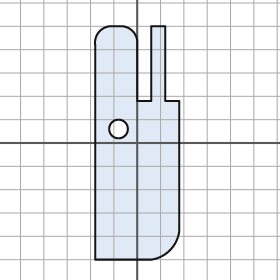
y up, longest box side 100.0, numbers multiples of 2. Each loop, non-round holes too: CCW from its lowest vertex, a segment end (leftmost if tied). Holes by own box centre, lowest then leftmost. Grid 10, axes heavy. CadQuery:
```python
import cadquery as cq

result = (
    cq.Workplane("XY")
    .moveTo(-18.0, -50.0)
    .lineTo(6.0, -50.0)
    .threePointArc((14.0, -46.0), (18.0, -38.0))
    .lineTo(18.0, 18.0)
    .lineTo(12.0, 18.0)
    .lineTo(12.0, 50.0)
    .lineTo(6.0, 50.0)
    .lineTo(6.0, 18.0)
    .lineTo(0.0, 18.0)
    .lineTo(0.0, 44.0)
    .threePointArc((-2.0, 48.0), (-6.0, 50.0))
    .lineTo(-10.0, 50.0)
    .threePointArc((-16.0, 48.0), (-18.0, 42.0))
    .close()
    .moveTo(-8.0, 6.0)
    .circle(4.0)
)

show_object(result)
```